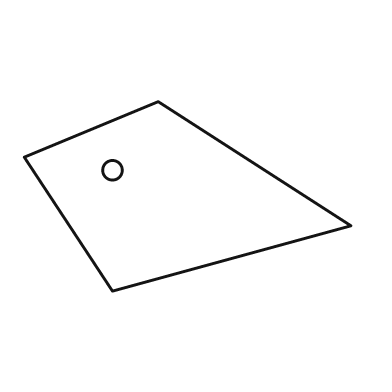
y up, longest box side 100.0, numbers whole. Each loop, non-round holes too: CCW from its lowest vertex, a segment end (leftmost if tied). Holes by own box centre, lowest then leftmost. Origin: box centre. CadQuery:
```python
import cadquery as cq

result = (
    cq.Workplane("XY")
    .moveTo(-23.0, -29.0)
    .lineTo(50.0, -9.0)
    .lineTo(-9.0, 29.0)
    .lineTo(-50.0, 12.0)
    .close()
    .moveTo(-23.0, 8.0)
    .circle(3.0)
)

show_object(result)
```